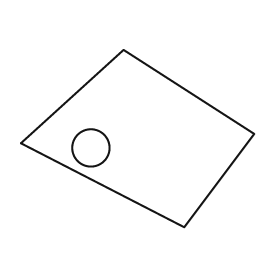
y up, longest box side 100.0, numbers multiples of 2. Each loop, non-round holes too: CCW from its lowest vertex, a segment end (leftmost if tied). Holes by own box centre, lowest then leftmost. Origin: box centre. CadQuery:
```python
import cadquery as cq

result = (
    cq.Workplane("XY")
    .moveTo(20.0, -38.0)
    .lineTo(50.0, 2.0)
    .lineTo(-6.0, 38.0)
    .lineTo(-50.0, -2.0)
    .close()
    .moveTo(-20.0, -4.0)
    .circle(8.0)
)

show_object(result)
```